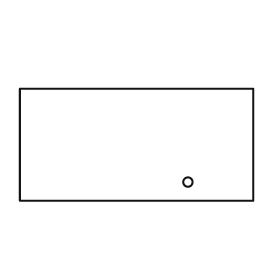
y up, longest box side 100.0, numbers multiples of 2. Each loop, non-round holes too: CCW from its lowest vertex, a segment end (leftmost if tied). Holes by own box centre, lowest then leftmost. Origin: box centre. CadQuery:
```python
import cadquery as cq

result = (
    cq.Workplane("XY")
    .moveTo(-50.0, -24.0)
    .lineTo(50.0, -24.0)
    .lineTo(50.0, 24.0)
    .lineTo(-50.0, 24.0)
    .close()
    .moveTo(22.0, -16.0)
    .circle(2.0)
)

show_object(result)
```